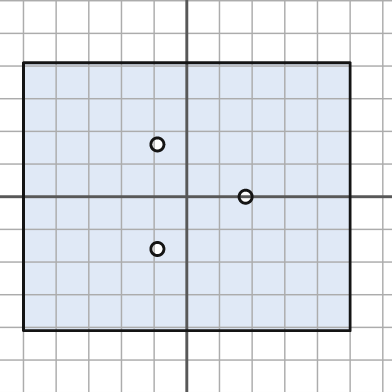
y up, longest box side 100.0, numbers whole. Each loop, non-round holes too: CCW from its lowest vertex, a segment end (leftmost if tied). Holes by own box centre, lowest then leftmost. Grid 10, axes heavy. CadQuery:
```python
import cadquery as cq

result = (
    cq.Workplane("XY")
    .moveTo(-50.0, -41.0)
    .lineTo(50.0, -41.0)
    .lineTo(50.0, 41.0)
    .lineTo(-50.0, 41.0)
    .close()
    .moveTo(-9.0, -16.0)
    .circle(2.0)
    .moveTo(18.0, 0.0)
    .circle(2.0)
    .moveTo(-9.0, 16.0)
    .circle(2.0)
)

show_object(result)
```